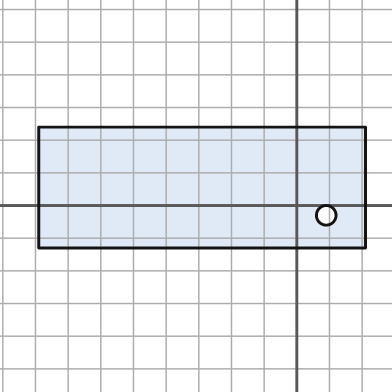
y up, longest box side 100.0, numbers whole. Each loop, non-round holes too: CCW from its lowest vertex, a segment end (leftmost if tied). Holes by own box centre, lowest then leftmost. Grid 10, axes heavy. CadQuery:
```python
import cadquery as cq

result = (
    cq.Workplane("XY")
    .moveTo(-79.0, -13.0)
    .lineTo(21.0, -13.0)
    .lineTo(21.0, 24.0)
    .lineTo(-79.0, 24.0)
    .close()
    .moveTo(9.0, -3.0)
    .circle(3.0)
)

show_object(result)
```